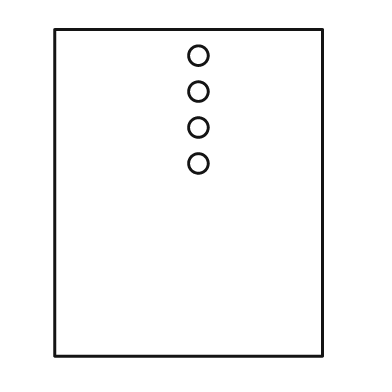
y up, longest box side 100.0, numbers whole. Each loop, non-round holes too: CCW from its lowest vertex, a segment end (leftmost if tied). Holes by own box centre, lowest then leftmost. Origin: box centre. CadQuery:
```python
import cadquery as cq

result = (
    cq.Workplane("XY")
    .moveTo(-41.0, -50.0)
    .lineTo(41.0, -50.0)
    .lineTo(41.0, 50.0)
    .lineTo(-41.0, 50.0)
    .close()
    .moveTo(3.0, 9.0)
    .circle(3.0)
    .moveTo(3.0, 20.0)
    .circle(3.0)
    .moveTo(3.0, 31.0)
    .circle(3.0)
    .moveTo(3.0, 42.0)
    .circle(3.0)
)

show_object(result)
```